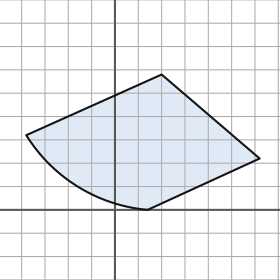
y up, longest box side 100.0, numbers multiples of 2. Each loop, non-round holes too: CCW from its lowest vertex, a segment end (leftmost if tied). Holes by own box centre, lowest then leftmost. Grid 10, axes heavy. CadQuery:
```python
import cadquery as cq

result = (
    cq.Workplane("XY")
    .moveTo(14.0, 0.0)
    .lineTo(62.0, 22.0)
    .lineTo(20.0, 58.0)
    .lineTo(-38.0, 32.0)
    .threePointArc((-16.0, 10.0), (14.0, 0.0))
    .close()
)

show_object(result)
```